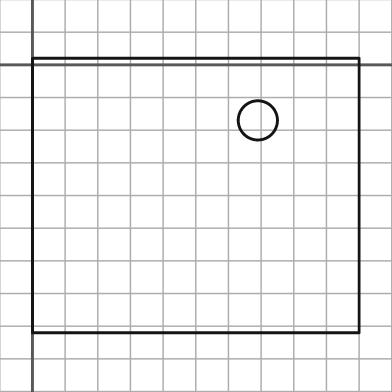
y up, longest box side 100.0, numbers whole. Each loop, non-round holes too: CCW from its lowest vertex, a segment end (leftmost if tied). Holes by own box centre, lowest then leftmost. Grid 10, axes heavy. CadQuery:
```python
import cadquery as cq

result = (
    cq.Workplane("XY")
    .moveTo(0.0, -82.0)
    .lineTo(100.0, -82.0)
    .lineTo(100.0, 2.0)
    .lineTo(0.0, 2.0)
    .close()
    .moveTo(69.0, -17.0)
    .circle(6.0)
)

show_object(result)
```